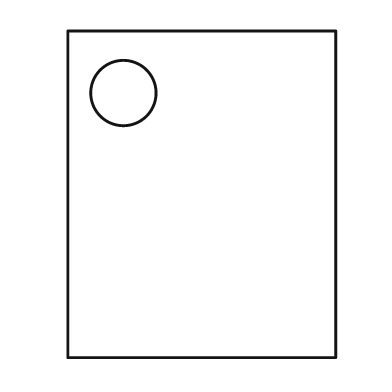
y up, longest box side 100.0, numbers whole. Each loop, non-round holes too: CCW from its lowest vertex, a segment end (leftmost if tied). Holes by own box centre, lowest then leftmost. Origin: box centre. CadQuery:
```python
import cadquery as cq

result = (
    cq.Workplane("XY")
    .moveTo(-41.0, -50.0)
    .lineTo(41.0, -50.0)
    .lineTo(41.0, 50.0)
    .lineTo(-41.0, 50.0)
    .close()
    .moveTo(-24.0, 31.0)
    .circle(10.0)
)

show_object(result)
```